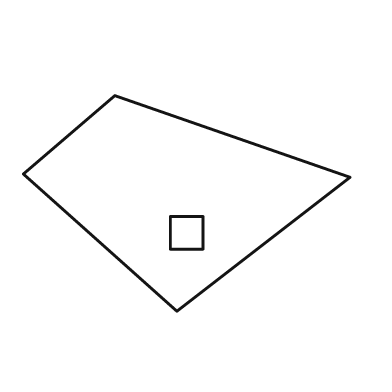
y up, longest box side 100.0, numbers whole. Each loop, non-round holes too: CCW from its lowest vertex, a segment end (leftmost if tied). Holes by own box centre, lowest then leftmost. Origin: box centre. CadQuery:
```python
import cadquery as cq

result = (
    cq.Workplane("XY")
    .moveTo(-3.0, -33.0)
    .lineTo(50.0, 8.0)
    .lineTo(-22.0, 33.0)
    .lineTo(-50.0, 9.0)
    .close()
    .moveTo(-5.0, -14.0)
    .lineTo(5.0, -14.0)
    .lineTo(5.0, -4.0)
    .lineTo(-5.0, -4.0)
    .close()
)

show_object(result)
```